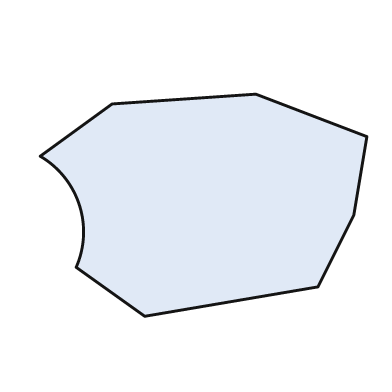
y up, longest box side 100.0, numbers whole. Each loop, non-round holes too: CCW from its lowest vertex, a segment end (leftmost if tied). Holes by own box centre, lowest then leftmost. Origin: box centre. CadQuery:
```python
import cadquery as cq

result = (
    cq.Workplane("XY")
    .moveTo(-18.0, -34.0)
    .lineTo(35.0, -25.0)
    .lineTo(46.0, -3.0)
    .lineTo(50.0, 21.0)
    .lineTo(16.0, 34.0)
    .lineTo(-28.0, 31.0)
    .lineTo(-50.0, 15.0)
    .threePointArc((-38.0, 0.0), (-39.0, -19.0))
    .close()
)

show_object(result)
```